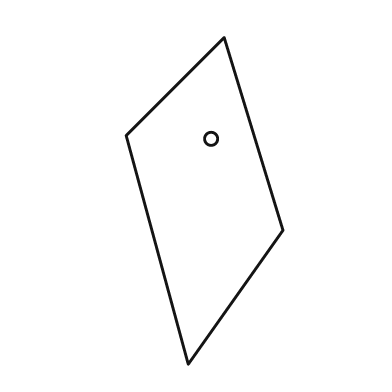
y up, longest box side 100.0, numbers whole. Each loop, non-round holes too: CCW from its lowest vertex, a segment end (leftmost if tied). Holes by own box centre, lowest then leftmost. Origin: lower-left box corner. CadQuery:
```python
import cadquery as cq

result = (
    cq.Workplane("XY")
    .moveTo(19.0, 0.0)
    .lineTo(48.0, 41.0)
    .lineTo(30.0, 100.0)
    .lineTo(0.0, 70.0)
    .close()
    .moveTo(26.0, 69.0)
    .circle(2.0)
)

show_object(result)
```